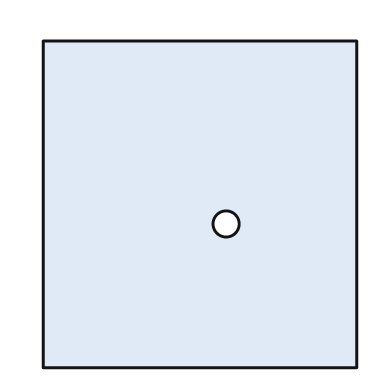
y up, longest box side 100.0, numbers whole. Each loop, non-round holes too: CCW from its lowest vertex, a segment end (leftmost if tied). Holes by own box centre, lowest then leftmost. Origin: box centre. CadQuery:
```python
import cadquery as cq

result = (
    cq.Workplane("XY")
    .moveTo(-48.0, -50.0)
    .lineTo(48.0, -50.0)
    .lineTo(48.0, 50.0)
    .lineTo(-48.0, 50.0)
    .close()
    .moveTo(8.0, -6.0)
    .circle(4.0)
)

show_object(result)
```